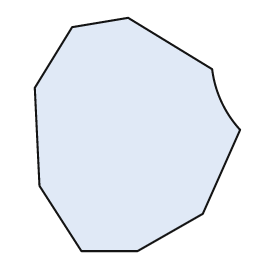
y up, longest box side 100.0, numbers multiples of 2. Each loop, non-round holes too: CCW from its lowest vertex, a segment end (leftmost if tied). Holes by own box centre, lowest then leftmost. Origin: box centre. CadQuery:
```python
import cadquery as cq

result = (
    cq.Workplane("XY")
    .moveTo(-24.0, -50.0)
    .lineTo(0.0, -50.0)
    .lineTo(28.0, -34.0)
    .lineTo(44.0, 2.0)
    .threePointArc((36.0, 14.0), (32.0, 28.0))
    .lineTo(-4.0, 50.0)
    .lineTo(-28.0, 46.0)
    .lineTo(-44.0, 20.0)
    .lineTo(-42.0, -22.0)
    .close()
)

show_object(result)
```